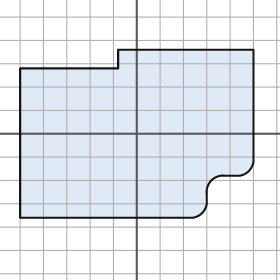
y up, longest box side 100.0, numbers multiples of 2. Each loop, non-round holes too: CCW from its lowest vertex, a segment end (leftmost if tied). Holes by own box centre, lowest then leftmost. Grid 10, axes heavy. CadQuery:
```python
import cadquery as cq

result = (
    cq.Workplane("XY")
    .moveTo(-50.0, -36.0)
    .lineTo(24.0, -36.0)
    .threePointArc((28.0, -34.0), (30.0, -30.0))
    .lineTo(30.0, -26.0)
    .threePointArc((32.0, -20.0), (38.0, -18.0))
    .lineTo(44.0, -18.0)
    .threePointArc((48.0, -16.0), (50.0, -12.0))
    .lineTo(50.0, 36.0)
    .lineTo(-8.0, 36.0)
    .lineTo(-8.0, 28.0)
    .lineTo(-50.0, 28.0)
    .close()
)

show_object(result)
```